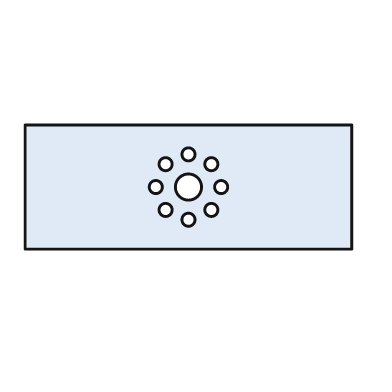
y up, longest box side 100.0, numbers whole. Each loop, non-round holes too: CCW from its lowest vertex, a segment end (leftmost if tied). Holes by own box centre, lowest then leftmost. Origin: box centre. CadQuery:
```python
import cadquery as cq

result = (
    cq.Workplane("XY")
    .moveTo(-50.0, -19.0)
    .lineTo(50.0, -19.0)
    .lineTo(50.0, 19.0)
    .lineTo(-50.0, 19.0)
    .close()
    .moveTo(0.0, -10.0)
    .circle(2.0)
    .moveTo(-7.0, -7.0)
    .circle(2.0)
    .moveTo(7.0, -7.0)
    .circle(2.0)
    .moveTo(-10.0, 0.0)
    .circle(2.0)
    .moveTo(0.0, 0.0)
    .circle(4.0)
    .moveTo(10.0, 0.0)
    .circle(2.0)
    .moveTo(-7.0, 7.0)
    .circle(2.0)
    .moveTo(7.0, 7.0)
    .circle(2.0)
    .moveTo(0.0, 10.0)
    .circle(2.0)
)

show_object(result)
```